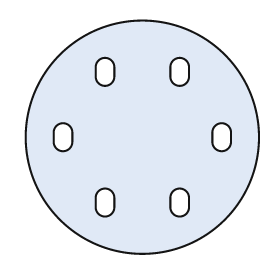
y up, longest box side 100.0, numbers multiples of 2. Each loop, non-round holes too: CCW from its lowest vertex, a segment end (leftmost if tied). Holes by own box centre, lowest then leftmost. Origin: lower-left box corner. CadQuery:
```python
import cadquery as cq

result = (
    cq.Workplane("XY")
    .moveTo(50.0, 50.0)
    .circle(50.0)
    .moveTo(30.0, 20.0)
    .threePointArc((34.0, 16.0), (38.0, 20.0))
    .lineTo(38.0, 24.0)
    .threePointArc((34.0, 28.0), (30.0, 24.0))
    .close()
    .moveTo(62.0, 20.0)
    .threePointArc((66.0, 16.0), (70.0, 20.0))
    .lineTo(70.0, 24.0)
    .threePointArc((66.0, 28.0), (62.0, 24.0))
    .close()
    .moveTo(12.0, 48.0)
    .threePointArc((16.0, 44.0), (20.0, 48.0))
    .lineTo(20.0, 52.0)
    .threePointArc((16.0, 56.0), (12.0, 52.0))
    .close()
    .moveTo(80.0, 48.0)
    .threePointArc((84.0, 44.0), (88.0, 48.0))
    .lineTo(88.0, 52.0)
    .threePointArc((84.0, 56.0), (80.0, 52.0))
    .close()
    .moveTo(30.0, 76.0)
    .threePointArc((34.0, 72.0), (38.0, 76.0))
    .lineTo(38.0, 80.0)
    .threePointArc((34.0, 84.0), (30.0, 80.0))
    .close()
    .moveTo(62.0, 76.0)
    .threePointArc((66.0, 72.0), (70.0, 76.0))
    .lineTo(70.0, 80.0)
    .threePointArc((66.0, 84.0), (62.0, 80.0))
    .close()
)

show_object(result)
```